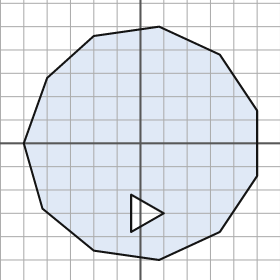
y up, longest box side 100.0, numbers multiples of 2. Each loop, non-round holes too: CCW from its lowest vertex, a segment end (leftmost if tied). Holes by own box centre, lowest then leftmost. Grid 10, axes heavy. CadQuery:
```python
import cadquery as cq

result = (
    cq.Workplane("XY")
    .moveTo(8.0, -50.0)
    .lineTo(34.0, -38.0)
    .lineTo(50.0, -14.0)
    .lineTo(50.0, 14.0)
    .lineTo(34.0, 38.0)
    .lineTo(8.0, 50.0)
    .lineTo(-20.0, 46.0)
    .lineTo(-40.0, 28.0)
    .lineTo(-50.0, 0.0)
    .lineTo(-42.0, -28.0)
    .lineTo(-20.0, -46.0)
    .close()
    .moveTo(-4.0, -38.0)
    .lineTo(10.0, -30.0)
    .lineTo(-4.0, -22.0)
    .close()
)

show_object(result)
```